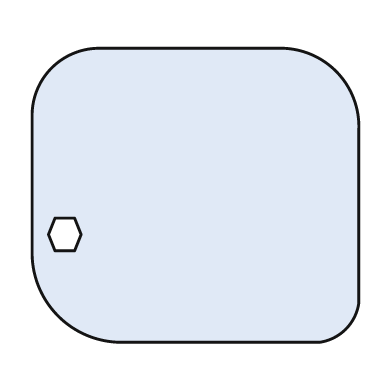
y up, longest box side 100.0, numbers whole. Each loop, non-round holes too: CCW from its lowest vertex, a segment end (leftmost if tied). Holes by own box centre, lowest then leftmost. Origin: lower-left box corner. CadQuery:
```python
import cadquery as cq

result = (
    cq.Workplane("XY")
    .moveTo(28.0, 0.0)
    .lineTo(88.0, 0.0)
    .threePointArc((96.0, 4.0), (100.0, 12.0))
    .lineTo(100.0, 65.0)
    .threePointArc((93.0, 83.0), (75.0, 90.0))
    .lineTo(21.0, 90.0)
    .threePointArc((6.0, 84.0), (0.0, 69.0))
    .lineTo(0.0, 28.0)
    .threePointArc((8.0, 8.0), (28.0, 0.0))
    .close()
    .moveTo(7.0, 28.0)
    .lineTo(13.0, 28.0)
    .lineTo(15.0, 33.0)
    .lineTo(13.0, 38.0)
    .lineTo(7.0, 38.0)
    .lineTo(5.0, 33.0)
    .close()
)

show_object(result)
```